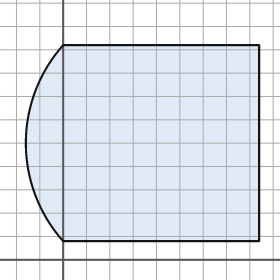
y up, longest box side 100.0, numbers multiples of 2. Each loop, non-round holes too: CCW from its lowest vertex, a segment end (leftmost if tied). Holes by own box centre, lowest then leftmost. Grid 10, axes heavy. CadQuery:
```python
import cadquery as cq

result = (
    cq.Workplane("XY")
    .moveTo(0.0, 8.0)
    .lineTo(84.0, 8.0)
    .lineTo(84.0, 92.0)
    .lineTo(0.0, 92.0)
    .threePointArc((-16.0, 50.0), (0.0, 8.0))
    .close()
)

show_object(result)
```